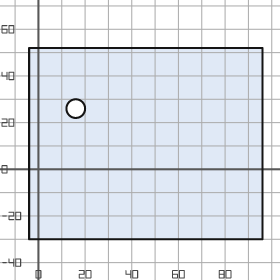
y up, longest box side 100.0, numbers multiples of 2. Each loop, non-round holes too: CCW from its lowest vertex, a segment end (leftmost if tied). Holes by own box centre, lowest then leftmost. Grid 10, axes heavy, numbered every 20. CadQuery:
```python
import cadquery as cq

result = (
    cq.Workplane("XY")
    .moveTo(-4.0, -30.0)
    .lineTo(96.0, -30.0)
    .lineTo(96.0, 52.0)
    .lineTo(-4.0, 52.0)
    .close()
    .moveTo(16.0, 26.0)
    .circle(4.0)
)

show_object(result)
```